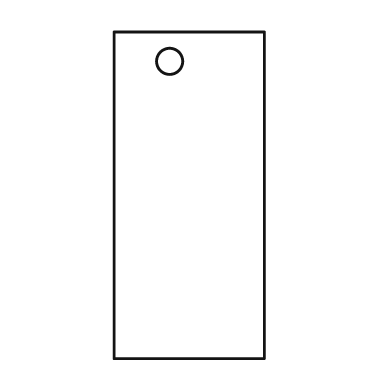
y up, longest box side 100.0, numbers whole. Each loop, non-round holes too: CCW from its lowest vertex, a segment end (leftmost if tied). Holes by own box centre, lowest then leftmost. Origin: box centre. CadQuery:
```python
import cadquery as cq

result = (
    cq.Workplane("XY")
    .moveTo(-23.0, -50.0)
    .lineTo(23.0, -50.0)
    .lineTo(23.0, 50.0)
    .lineTo(-23.0, 50.0)
    .close()
    .moveTo(-6.0, 41.0)
    .circle(4.0)
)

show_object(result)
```